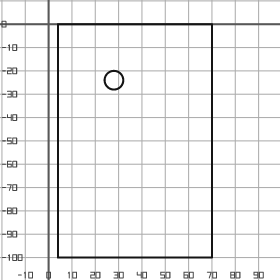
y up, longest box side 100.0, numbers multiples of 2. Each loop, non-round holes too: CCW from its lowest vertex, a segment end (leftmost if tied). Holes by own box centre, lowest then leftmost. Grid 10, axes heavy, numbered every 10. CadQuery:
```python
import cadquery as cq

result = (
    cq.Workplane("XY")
    .moveTo(4.0, -100.0)
    .lineTo(70.0, -100.0)
    .lineTo(70.0, 0.0)
    .lineTo(4.0, 0.0)
    .close()
    .moveTo(28.0, -24.0)
    .circle(4.0)
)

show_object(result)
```